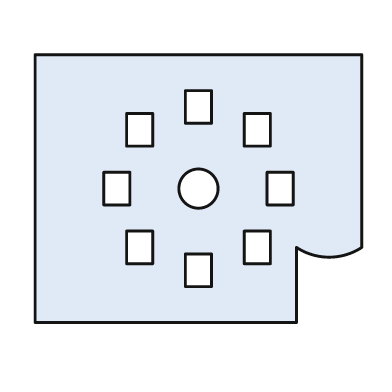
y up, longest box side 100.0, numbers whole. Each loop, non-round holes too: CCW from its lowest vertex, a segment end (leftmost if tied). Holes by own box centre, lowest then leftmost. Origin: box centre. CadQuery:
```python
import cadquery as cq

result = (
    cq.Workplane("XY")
    .moveTo(-50.0, -41.0)
    .lineTo(30.0, -41.0)
    .lineTo(30.0, -18.0)
    .threePointArc((40.0, -21.0), (50.0, -18.0))
    .lineTo(50.0, 41.0)
    .lineTo(-50.0, 41.0)
    .close()
    .moveTo(-4.0, -30.0)
    .lineTo(4.0, -30.0)
    .lineTo(4.0, -20.0)
    .lineTo(-4.0, -20.0)
    .close()
    .moveTo(-22.0, -23.0)
    .lineTo(-14.0, -23.0)
    .lineTo(-14.0, -13.0)
    .lineTo(-22.0, -13.0)
    .close()
    .moveTo(14.0, -23.0)
    .lineTo(22.0, -23.0)
    .lineTo(22.0, -13.0)
    .lineTo(14.0, -13.0)
    .close()
    .moveTo(-29.0, -5.0)
    .lineTo(-21.0, -5.0)
    .lineTo(-21.0, 5.0)
    .lineTo(-29.0, 5.0)
    .close()
    .moveTo(0.0, 0.0)
    .circle(6.0)
    .moveTo(21.0, -5.0)
    .lineTo(29.0, -5.0)
    .lineTo(29.0, 5.0)
    .lineTo(21.0, 5.0)
    .close()
    .moveTo(-22.0, 13.0)
    .lineTo(-14.0, 13.0)
    .lineTo(-14.0, 23.0)
    .lineTo(-22.0, 23.0)
    .close()
    .moveTo(14.0, 13.0)
    .lineTo(22.0, 13.0)
    .lineTo(22.0, 23.0)
    .lineTo(14.0, 23.0)
    .close()
    .moveTo(-4.0, 20.0)
    .lineTo(4.0, 20.0)
    .lineTo(4.0, 30.0)
    .lineTo(-4.0, 30.0)
    .close()
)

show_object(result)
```